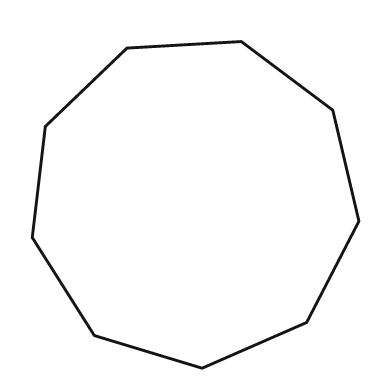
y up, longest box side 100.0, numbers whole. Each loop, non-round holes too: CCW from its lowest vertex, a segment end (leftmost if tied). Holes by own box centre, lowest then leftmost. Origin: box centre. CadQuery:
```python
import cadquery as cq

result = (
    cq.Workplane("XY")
    .moveTo(2.0, -50.0)
    .lineTo(34.0, -36.0)
    .lineTo(50.0, -5.0)
    .lineTo(42.0, 29.0)
    .lineTo(14.0, 50.0)
    .lineTo(-21.0, 48.0)
    .lineTo(-46.0, 24.0)
    .lineTo(-50.0, -10.0)
    .lineTo(-31.0, -40.0)
    .close()
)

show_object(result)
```